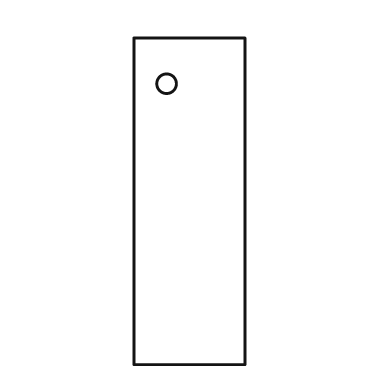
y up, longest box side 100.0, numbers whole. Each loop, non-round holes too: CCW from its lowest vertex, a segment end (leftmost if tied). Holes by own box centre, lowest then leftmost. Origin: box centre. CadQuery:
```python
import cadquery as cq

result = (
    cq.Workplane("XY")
    .moveTo(-17.0, -50.0)
    .lineTo(17.0, -50.0)
    .lineTo(17.0, 50.0)
    .lineTo(-17.0, 50.0)
    .close()
    .moveTo(-7.0, 36.0)
    .circle(3.0)
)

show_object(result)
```